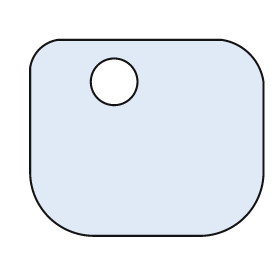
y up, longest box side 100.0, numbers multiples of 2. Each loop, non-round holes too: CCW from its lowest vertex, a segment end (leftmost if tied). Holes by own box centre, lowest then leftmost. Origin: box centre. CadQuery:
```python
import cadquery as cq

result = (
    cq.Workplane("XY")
    .moveTo(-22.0, -42.0)
    .lineTo(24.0, -42.0)
    .threePointArc((42.0, -34.0), (50.0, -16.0))
    .lineTo(50.0, 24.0)
    .threePointArc((44.0, 36.0), (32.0, 42.0))
    .lineTo(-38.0, 42.0)
    .threePointArc((-46.0, 38.0), (-50.0, 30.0))
    .lineTo(-50.0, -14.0)
    .threePointArc((-42.0, -34.0), (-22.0, -42.0))
    .close()
    .moveTo(-14.0, 24.0)
    .circle(10.0)
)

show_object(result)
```